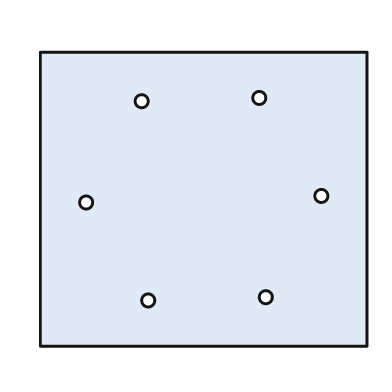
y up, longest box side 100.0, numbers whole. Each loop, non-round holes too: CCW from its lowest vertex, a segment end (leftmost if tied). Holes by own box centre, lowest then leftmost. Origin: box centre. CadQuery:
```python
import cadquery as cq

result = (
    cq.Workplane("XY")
    .moveTo(-50.0, -45.0)
    .lineTo(50.0, -45.0)
    .lineTo(50.0, 45.0)
    .lineTo(-50.0, 45.0)
    .close()
    .moveTo(-17.0, -31.0)
    .circle(2.0)
    .moveTo(19.0, -30.0)
    .circle(2.0)
    .moveTo(-36.0, -1.0)
    .circle(2.0)
    .moveTo(36.0, 1.0)
    .circle(2.0)
    .moveTo(-19.0, 30.0)
    .circle(2.0)
    .moveTo(17.0, 31.0)
    .circle(2.0)
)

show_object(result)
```